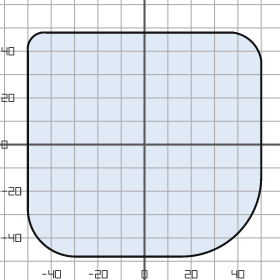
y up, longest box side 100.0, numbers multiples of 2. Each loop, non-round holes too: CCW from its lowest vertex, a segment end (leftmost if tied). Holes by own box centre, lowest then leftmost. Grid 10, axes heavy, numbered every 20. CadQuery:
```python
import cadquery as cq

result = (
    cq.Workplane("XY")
    .moveTo(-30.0, -48.0)
    .lineTo(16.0, -48.0)
    .threePointArc((40.0, -38.0), (50.0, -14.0))
    .lineTo(50.0, 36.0)
    .threePointArc((46.0, 44.0), (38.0, 48.0))
    .lineTo(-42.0, 48.0)
    .threePointArc((-48.0, 46.0), (-50.0, 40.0))
    .lineTo(-50.0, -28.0)
    .threePointArc((-44.0, -42.0), (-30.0, -48.0))
    .close()
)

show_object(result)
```